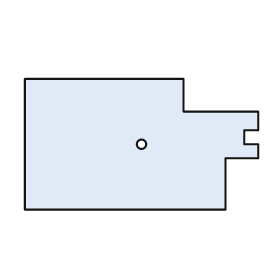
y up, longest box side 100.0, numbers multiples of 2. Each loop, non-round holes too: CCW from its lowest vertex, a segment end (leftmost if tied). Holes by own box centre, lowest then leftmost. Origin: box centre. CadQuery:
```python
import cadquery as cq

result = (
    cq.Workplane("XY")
    .moveTo(-50.0, -28.0)
    .lineTo(36.0, -28.0)
    .lineTo(36.0, -6.0)
    .lineTo(50.0, -6.0)
    .lineTo(50.0, 0.0)
    .lineTo(44.0, 0.0)
    .lineTo(44.0, 6.0)
    .lineTo(50.0, 6.0)
    .lineTo(50.0, 14.0)
    .lineTo(18.0, 14.0)
    .lineTo(18.0, 28.0)
    .lineTo(-50.0, 28.0)
    .close()
    .moveTo(0.0, 0.0)
    .circle(2.0)
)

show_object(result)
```